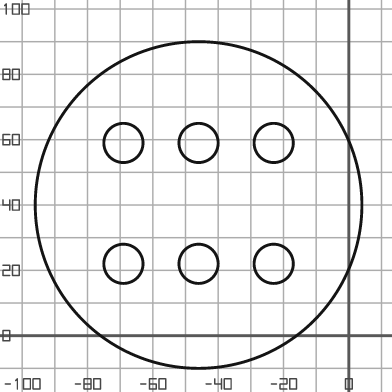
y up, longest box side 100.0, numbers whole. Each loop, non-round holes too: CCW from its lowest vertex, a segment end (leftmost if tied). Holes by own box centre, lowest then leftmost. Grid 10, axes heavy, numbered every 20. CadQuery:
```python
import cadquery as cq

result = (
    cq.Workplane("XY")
    .moveTo(-46.0, 40.0)
    .circle(50.0)
    .moveTo(-69.0, 22.0)
    .circle(6.0)
    .moveTo(-46.0, 22.0)
    .circle(6.0)
    .moveTo(-23.0, 22.0)
    .circle(6.0)
    .moveTo(-69.0, 59.0)
    .circle(6.0)
    .moveTo(-46.0, 59.0)
    .circle(6.0)
    .moveTo(-23.0, 59.0)
    .circle(6.0)
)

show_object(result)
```